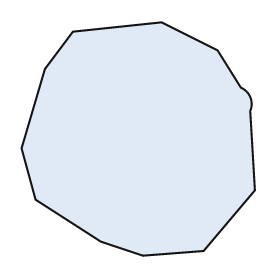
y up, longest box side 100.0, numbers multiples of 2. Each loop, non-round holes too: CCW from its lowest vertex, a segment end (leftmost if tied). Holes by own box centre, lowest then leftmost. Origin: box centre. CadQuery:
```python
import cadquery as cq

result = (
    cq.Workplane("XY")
    .moveTo(2.0, -50.0)
    .lineTo(28.0, -48.0)
    .lineTo(50.0, -22.0)
    .lineTo(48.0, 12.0)
    .threePointArc((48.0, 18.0), (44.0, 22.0))
    .lineTo(34.0, 38.0)
    .lineTo(10.0, 50.0)
    .lineTo(-28.0, 46.0)
    .lineTo(-40.0, 30.0)
    .lineTo(-50.0, -4.0)
    .lineTo(-44.0, -26.0)
    .lineTo(-16.0, -44.0)
    .close()
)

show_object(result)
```